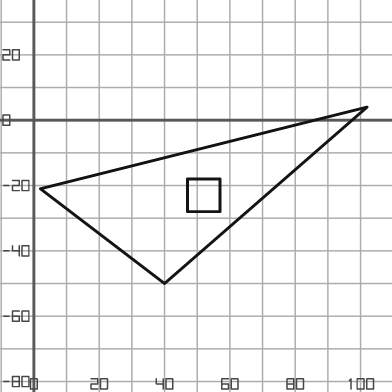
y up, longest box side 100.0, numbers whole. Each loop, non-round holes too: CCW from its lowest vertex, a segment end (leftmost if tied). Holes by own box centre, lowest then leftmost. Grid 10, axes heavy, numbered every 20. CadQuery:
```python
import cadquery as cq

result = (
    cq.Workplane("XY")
    .moveTo(40.0, -50.0)
    .lineTo(102.0, 4.0)
    .lineTo(2.0, -21.0)
    .close()
    .moveTo(47.0, -28.0)
    .lineTo(57.0, -28.0)
    .lineTo(57.0, -18.0)
    .lineTo(47.0, -18.0)
    .close()
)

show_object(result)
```